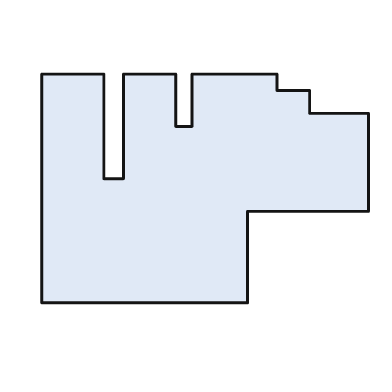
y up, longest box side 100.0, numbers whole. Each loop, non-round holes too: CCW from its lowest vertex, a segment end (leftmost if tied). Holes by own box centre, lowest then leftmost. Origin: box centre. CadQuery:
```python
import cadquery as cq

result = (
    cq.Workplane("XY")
    .moveTo(-50.0, -35.0)
    .lineTo(13.0, -35.0)
    .lineTo(13.0, -7.0)
    .lineTo(50.0, -7.0)
    .lineTo(50.0, 23.0)
    .lineTo(32.0, 23.0)
    .lineTo(32.0, 30.0)
    .lineTo(22.0, 30.0)
    .lineTo(22.0, 35.0)
    .lineTo(-4.0, 35.0)
    .lineTo(-4.0, 19.0)
    .lineTo(-9.0, 19.0)
    .lineTo(-9.0, 35.0)
    .lineTo(-25.0, 35.0)
    .lineTo(-25.0, 3.0)
    .lineTo(-31.0, 3.0)
    .lineTo(-31.0, 35.0)
    .lineTo(-50.0, 35.0)
    .close()
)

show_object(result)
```